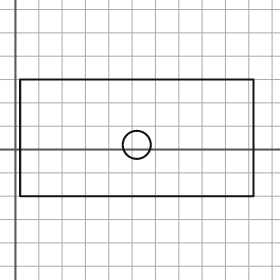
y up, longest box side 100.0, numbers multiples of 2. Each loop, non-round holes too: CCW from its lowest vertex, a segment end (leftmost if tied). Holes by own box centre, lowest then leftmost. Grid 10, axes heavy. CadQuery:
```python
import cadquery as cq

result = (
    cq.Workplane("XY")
    .moveTo(2.0, -20.0)
    .lineTo(102.0, -20.0)
    .lineTo(102.0, 30.0)
    .lineTo(2.0, 30.0)
    .close()
    .moveTo(52.0, 2.0)
    .circle(6.0)
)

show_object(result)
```